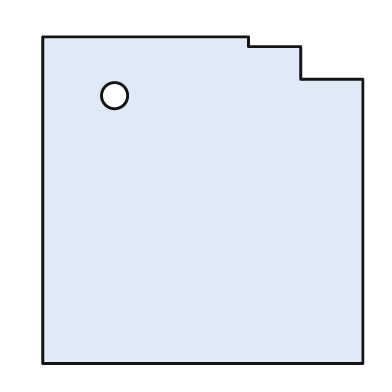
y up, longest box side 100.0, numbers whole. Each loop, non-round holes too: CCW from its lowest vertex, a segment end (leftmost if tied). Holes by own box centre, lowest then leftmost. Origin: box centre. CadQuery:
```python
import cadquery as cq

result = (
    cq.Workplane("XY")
    .moveTo(-49.0, -50.0)
    .lineTo(49.0, -50.0)
    .lineTo(49.0, 37.0)
    .lineTo(30.0, 37.0)
    .lineTo(30.0, 47.0)
    .lineTo(14.0, 47.0)
    .lineTo(14.0, 50.0)
    .lineTo(-49.0, 50.0)
    .close()
    .moveTo(-27.0, 32.0)
    .circle(4.0)
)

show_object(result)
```